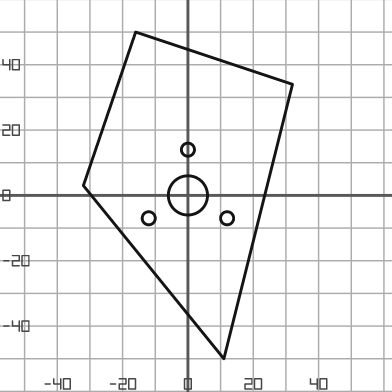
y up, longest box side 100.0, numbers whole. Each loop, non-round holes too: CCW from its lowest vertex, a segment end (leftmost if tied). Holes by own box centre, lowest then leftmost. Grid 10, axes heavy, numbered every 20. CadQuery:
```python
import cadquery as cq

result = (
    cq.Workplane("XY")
    .moveTo(11.0, -50.0)
    .lineTo(32.0, 34.0)
    .lineTo(-16.0, 50.0)
    .lineTo(-32.0, 3.0)
    .close()
    .moveTo(-12.0, -7.0)
    .circle(2.0)
    .moveTo(12.0, -7.0)
    .circle(2.0)
    .moveTo(0.0, 0.0)
    .circle(6.0)
    .moveTo(0.0, 14.0)
    .circle(2.0)
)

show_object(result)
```